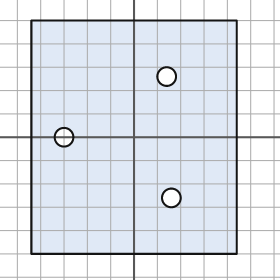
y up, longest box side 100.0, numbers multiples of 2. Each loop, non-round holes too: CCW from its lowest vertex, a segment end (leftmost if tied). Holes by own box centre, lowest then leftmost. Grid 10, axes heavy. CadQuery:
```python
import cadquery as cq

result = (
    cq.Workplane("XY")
    .moveTo(-44.0, -50.0)
    .lineTo(44.0, -50.0)
    .lineTo(44.0, 50.0)
    .lineTo(-44.0, 50.0)
    .close()
    .moveTo(16.0, -26.0)
    .circle(4.0)
    .moveTo(-30.0, 0.0)
    .circle(4.0)
    .moveTo(14.0, 26.0)
    .circle(4.0)
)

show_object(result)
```